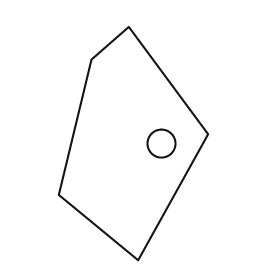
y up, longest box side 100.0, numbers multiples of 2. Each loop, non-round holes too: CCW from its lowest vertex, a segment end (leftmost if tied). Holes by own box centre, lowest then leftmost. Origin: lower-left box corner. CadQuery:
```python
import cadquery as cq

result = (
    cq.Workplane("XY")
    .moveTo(34.0, 0.0)
    .lineTo(64.0, 54.0)
    .lineTo(30.0, 100.0)
    .lineTo(14.0, 86.0)
    .lineTo(0.0, 28.0)
    .close()
    .moveTo(44.0, 50.0)
    .circle(6.0)
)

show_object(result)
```